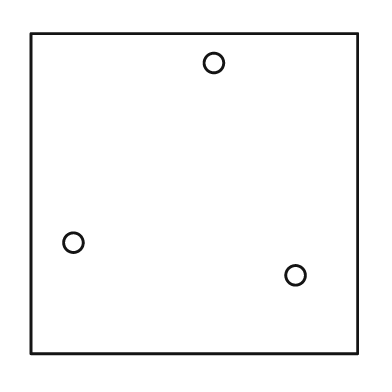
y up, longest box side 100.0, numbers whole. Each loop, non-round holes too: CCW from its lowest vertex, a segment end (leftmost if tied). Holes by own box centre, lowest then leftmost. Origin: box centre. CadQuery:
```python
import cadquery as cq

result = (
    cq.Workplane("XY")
    .moveTo(-50.0, -49.0)
    .lineTo(50.0, -49.0)
    .lineTo(50.0, 49.0)
    .lineTo(-50.0, 49.0)
    .close()
    .moveTo(31.0, -25.0)
    .circle(3.0)
    .moveTo(-37.0, -15.0)
    .circle(3.0)
    .moveTo(6.0, 40.0)
    .circle(3.0)
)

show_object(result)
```